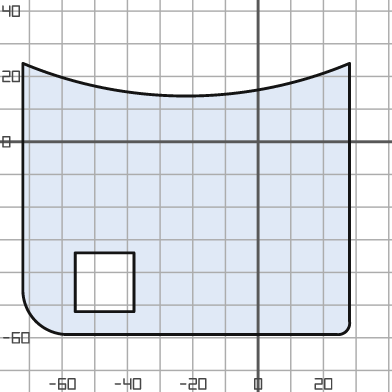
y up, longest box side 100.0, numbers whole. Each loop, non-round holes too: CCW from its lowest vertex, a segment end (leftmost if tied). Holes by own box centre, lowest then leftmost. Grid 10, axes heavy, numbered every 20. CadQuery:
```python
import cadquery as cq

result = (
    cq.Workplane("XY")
    .moveTo(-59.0, -59.0)
    .lineTo(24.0, -59.0)
    .threePointArc((27.0, -58.0), (28.0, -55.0))
    .lineTo(28.0, 24.0)
    .threePointArc((-22.0, 14.0), (-72.0, 24.0))
    .lineTo(-72.0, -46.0)
    .threePointArc((-68.0, -55.0), (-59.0, -59.0))
    .close()
    .moveTo(-56.0, -52.0)
    .lineTo(-38.0, -52.0)
    .lineTo(-38.0, -34.0)
    .lineTo(-56.0, -34.0)
    .close()
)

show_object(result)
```